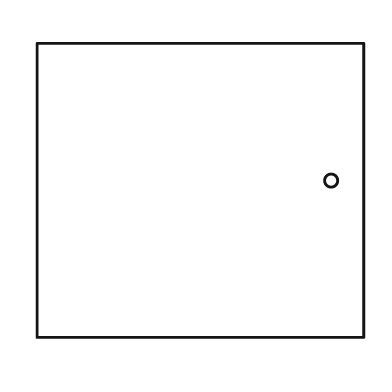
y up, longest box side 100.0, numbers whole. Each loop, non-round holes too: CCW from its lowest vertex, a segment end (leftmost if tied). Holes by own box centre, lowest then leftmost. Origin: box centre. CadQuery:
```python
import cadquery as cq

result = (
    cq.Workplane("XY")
    .moveTo(-50.0, -45.0)
    .lineTo(50.0, -45.0)
    .lineTo(50.0, 45.0)
    .lineTo(-50.0, 45.0)
    .close()
    .moveTo(40.0, 3.0)
    .circle(2.0)
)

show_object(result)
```